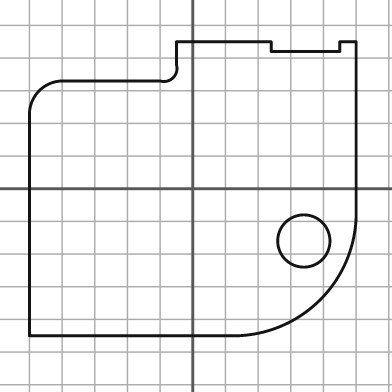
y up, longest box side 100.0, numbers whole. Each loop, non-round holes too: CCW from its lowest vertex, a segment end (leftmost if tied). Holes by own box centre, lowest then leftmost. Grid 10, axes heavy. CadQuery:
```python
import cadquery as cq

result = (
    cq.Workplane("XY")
    .moveTo(-50.0, -45.0)
    .lineTo(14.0, -45.0)
    .threePointArc((39.0, -34.0), (50.0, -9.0))
    .lineTo(50.0, 45.0)
    .lineTo(45.0, 45.0)
    .lineTo(45.0, 42.0)
    .lineTo(24.0, 42.0)
    .lineTo(24.0, 45.0)
    .lineTo(-5.0, 45.0)
    .lineTo(-5.0, 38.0)
    .threePointArc((-6.0, 34.0), (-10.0, 33.0))
    .lineTo(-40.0, 33.0)
    .threePointArc((-47.0, 30.0), (-50.0, 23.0))
    .close()
    .moveTo(34.0, -16.0)
    .circle(8.0)
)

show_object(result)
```